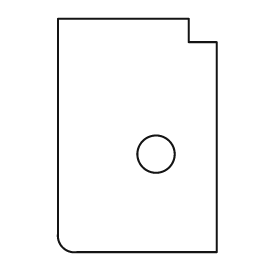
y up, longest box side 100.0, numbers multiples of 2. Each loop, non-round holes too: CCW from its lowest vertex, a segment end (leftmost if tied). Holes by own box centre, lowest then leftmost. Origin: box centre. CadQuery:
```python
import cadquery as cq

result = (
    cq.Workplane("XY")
    .moveTo(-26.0, -50.0)
    .lineTo(34.0, -50.0)
    .lineTo(34.0, 40.0)
    .lineTo(22.0, 40.0)
    .lineTo(22.0, 50.0)
    .lineTo(-34.0, 50.0)
    .lineTo(-34.0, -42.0)
    .threePointArc((-32.0, -48.0), (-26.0, -50.0))
    .close()
    .moveTo(8.0, -8.0)
    .circle(8.0)
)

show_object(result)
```